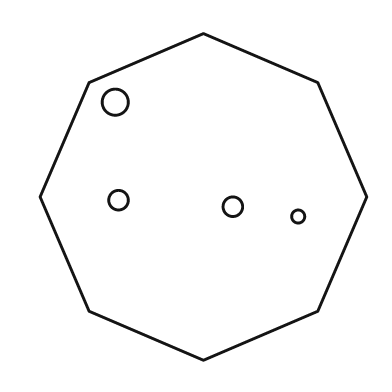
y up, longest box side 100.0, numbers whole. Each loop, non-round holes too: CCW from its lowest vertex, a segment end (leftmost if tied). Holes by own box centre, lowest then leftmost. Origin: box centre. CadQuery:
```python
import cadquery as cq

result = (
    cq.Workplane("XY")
    .moveTo(0.0, -50.0)
    .lineTo(35.0, -35.0)
    .lineTo(50.0, 0.0)
    .lineTo(35.0, 35.0)
    .lineTo(0.0, 50.0)
    .lineTo(-35.0, 35.0)
    .lineTo(-50.0, 0.0)
    .lineTo(-35.0, -35.0)
    .close()
    .moveTo(29.0, -6.0)
    .circle(2.0)
    .moveTo(9.0, -3.0)
    .circle(3.0)
    .moveTo(-26.0, -1.0)
    .circle(3.0)
    .moveTo(-27.0, 29.0)
    .circle(4.0)
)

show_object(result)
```